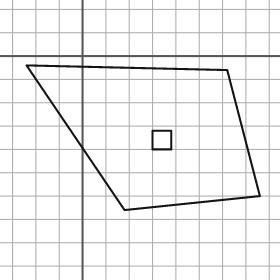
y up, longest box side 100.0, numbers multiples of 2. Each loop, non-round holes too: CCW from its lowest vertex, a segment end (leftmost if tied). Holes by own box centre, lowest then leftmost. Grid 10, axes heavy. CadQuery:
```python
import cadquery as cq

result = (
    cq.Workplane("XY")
    .moveTo(18.0, -66.0)
    .lineTo(76.0, -60.0)
    .lineTo(62.0, -6.0)
    .lineTo(-24.0, -4.0)
    .close()
    .moveTo(30.0, -40.0)
    .lineTo(38.0, -40.0)
    .lineTo(38.0, -32.0)
    .lineTo(30.0, -32.0)
    .close()
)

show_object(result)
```